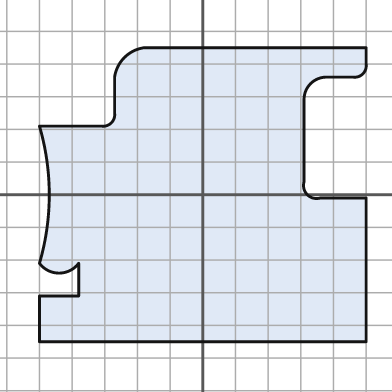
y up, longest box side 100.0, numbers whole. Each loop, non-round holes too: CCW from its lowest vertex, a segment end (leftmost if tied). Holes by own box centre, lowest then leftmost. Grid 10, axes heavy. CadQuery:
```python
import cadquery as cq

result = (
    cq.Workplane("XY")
    .moveTo(-50.0, -45.0)
    .lineTo(50.0, -45.0)
    .lineTo(50.0, -1.0)
    .lineTo(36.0, -1.0)
    .threePointArc((32.0, 0.0), (31.0, 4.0))
    .lineTo(31.0, 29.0)
    .threePointArc((33.0, 34.0), (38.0, 36.0))
    .lineTo(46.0, 36.0)
    .threePointArc((49.0, 37.0), (50.0, 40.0))
    .lineTo(50.0, 45.0)
    .lineTo(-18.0, 45.0)
    .threePointArc((-24.0, 42.0), (-27.0, 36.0))
    .lineTo(-27.0, 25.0)
    .threePointArc((-28.0, 22.0), (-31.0, 21.0))
    .lineTo(-50.0, 21.0)
    .threePointArc((-47.0, 0.0), (-50.0, -21.0))
    .threePointArc((-44.0, -24.0), (-38.0, -21.0))
    .lineTo(-38.0, -31.0)
    .lineTo(-50.0, -31.0)
    .close()
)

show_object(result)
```